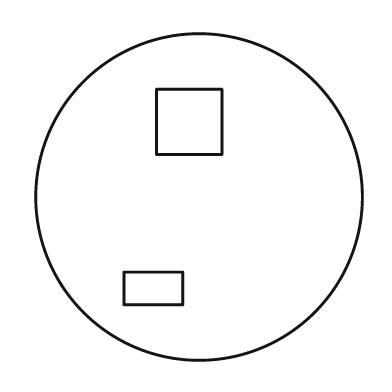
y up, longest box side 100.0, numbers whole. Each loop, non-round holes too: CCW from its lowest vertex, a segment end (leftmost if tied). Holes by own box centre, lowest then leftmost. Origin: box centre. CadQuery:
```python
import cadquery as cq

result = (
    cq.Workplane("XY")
    .moveTo(0.0, 0.0)
    .circle(50.0)
    .moveTo(-23.0, -33.0)
    .lineTo(-5.0, -33.0)
    .lineTo(-5.0, -23.0)
    .lineTo(-23.0, -23.0)
    .close()
    .moveTo(-13.0, 13.0)
    .lineTo(7.0, 13.0)
    .lineTo(7.0, 33.0)
    .lineTo(-13.0, 33.0)
    .close()
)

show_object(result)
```